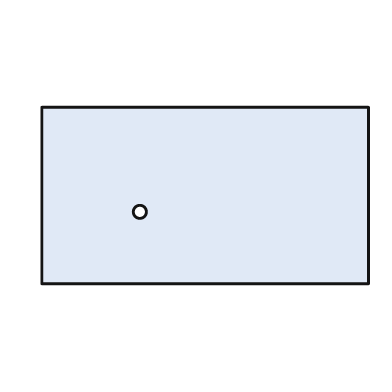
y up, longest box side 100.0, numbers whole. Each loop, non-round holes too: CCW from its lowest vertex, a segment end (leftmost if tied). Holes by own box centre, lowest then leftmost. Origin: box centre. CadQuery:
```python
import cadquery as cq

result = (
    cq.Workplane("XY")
    .moveTo(-50.0, -27.0)
    .lineTo(50.0, -27.0)
    .lineTo(50.0, 27.0)
    .lineTo(-50.0, 27.0)
    .close()
    .moveTo(-20.0, -5.0)
    .circle(2.0)
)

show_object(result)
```